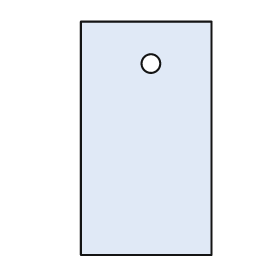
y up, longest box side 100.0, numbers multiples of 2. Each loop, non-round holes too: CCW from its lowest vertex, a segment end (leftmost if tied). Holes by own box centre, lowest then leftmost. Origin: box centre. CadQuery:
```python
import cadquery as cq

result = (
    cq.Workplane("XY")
    .moveTo(-28.0, -50.0)
    .lineTo(28.0, -50.0)
    .lineTo(28.0, 50.0)
    .lineTo(-28.0, 50.0)
    .close()
    .moveTo(2.0, 32.0)
    .circle(4.0)
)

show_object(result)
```